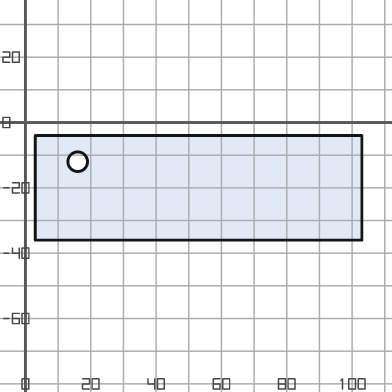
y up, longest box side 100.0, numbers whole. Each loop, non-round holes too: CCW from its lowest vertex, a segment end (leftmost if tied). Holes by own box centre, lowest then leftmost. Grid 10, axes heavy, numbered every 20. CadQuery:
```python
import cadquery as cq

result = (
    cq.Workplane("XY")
    .moveTo(3.0, -36.0)
    .lineTo(103.0, -36.0)
    .lineTo(103.0, -4.0)
    .lineTo(3.0, -4.0)
    .close()
    .moveTo(16.0, -12.0)
    .circle(3.0)
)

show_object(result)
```